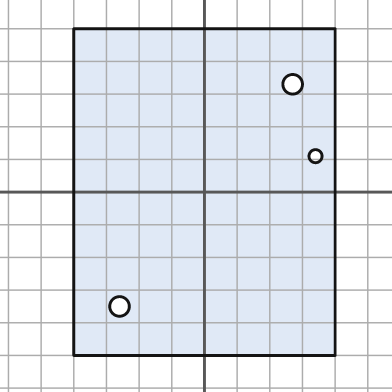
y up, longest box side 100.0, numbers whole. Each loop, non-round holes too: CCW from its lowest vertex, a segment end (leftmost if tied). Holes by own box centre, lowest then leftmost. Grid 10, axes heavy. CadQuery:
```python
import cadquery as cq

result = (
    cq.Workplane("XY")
    .moveTo(-40.0, -50.0)
    .lineTo(40.0, -50.0)
    .lineTo(40.0, 50.0)
    .lineTo(-40.0, 50.0)
    .close()
    .moveTo(-26.0, -35.0)
    .circle(3.0)
    .moveTo(34.0, 11.0)
    .circle(2.0)
    .moveTo(27.0, 33.0)
    .circle(3.0)
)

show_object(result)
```